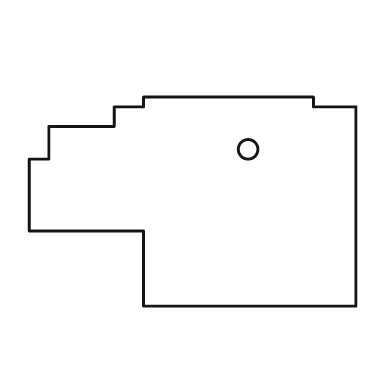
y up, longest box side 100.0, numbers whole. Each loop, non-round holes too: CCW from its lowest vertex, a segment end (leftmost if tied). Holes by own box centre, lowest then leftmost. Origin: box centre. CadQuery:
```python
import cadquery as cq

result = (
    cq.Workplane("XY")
    .moveTo(-15.0, -32.0)
    .lineTo(50.0, -32.0)
    .lineTo(50.0, 29.0)
    .lineTo(37.0, 29.0)
    .lineTo(37.0, 32.0)
    .lineTo(-15.0, 32.0)
    .lineTo(-15.0, 29.0)
    .lineTo(-24.0, 29.0)
    .lineTo(-24.0, 23.0)
    .lineTo(-44.0, 23.0)
    .lineTo(-44.0, 13.0)
    .lineTo(-50.0, 13.0)
    .lineTo(-50.0, -9.0)
    .lineTo(-15.0, -9.0)
    .close()
    .moveTo(17.0, 16.0)
    .circle(3.0)
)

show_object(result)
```